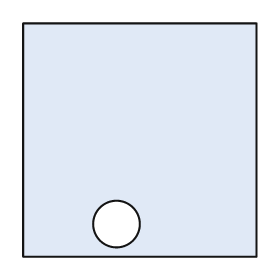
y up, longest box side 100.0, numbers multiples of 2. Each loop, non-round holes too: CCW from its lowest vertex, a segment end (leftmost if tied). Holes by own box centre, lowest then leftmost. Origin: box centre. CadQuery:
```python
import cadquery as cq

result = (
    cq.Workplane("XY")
    .moveTo(-50.0, -50.0)
    .lineTo(50.0, -50.0)
    .lineTo(50.0, 50.0)
    .lineTo(-50.0, 50.0)
    .close()
    .moveTo(-10.0, -36.0)
    .circle(10.0)
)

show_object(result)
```